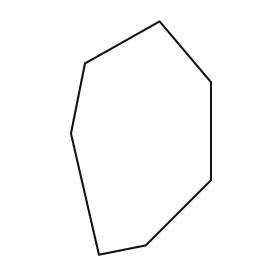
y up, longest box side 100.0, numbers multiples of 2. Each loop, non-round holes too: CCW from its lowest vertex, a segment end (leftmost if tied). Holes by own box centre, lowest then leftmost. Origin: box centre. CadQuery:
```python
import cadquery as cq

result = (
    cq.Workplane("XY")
    .moveTo(-18.0, -50.0)
    .lineTo(2.0, -46.0)
    .lineTo(30.0, -18.0)
    .lineTo(30.0, 24.0)
    .lineTo(8.0, 50.0)
    .lineTo(-24.0, 32.0)
    .lineTo(-30.0, 2.0)
    .close()
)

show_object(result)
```